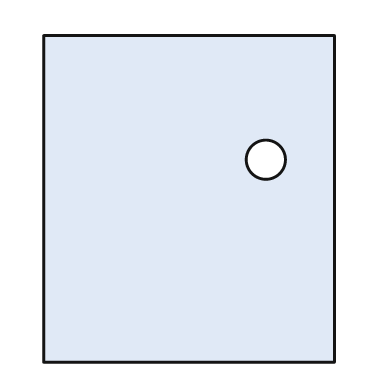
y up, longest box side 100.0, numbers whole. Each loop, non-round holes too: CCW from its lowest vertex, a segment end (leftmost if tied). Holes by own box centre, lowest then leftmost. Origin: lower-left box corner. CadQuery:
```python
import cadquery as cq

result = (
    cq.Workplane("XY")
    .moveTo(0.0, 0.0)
    .lineTo(89.0, 0.0)
    .lineTo(89.0, 100.0)
    .lineTo(0.0, 100.0)
    .close()
    .moveTo(68.0, 62.0)
    .circle(6.0)
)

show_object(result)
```